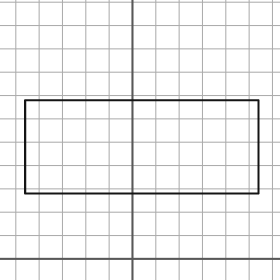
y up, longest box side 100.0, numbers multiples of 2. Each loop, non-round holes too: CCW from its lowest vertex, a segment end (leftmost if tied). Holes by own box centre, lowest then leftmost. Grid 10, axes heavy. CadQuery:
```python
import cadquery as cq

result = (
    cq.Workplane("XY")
    .moveTo(-46.0, 28.0)
    .lineTo(54.0, 28.0)
    .lineTo(54.0, 68.0)
    .lineTo(-46.0, 68.0)
    .close()
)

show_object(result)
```